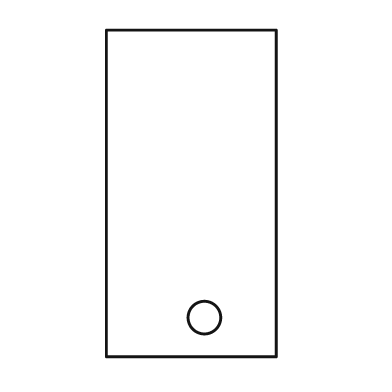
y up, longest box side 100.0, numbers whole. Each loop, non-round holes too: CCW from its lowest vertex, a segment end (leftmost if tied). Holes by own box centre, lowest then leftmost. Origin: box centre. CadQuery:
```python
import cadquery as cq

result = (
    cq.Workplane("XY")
    .moveTo(-26.0, -50.0)
    .lineTo(26.0, -50.0)
    .lineTo(26.0, 50.0)
    .lineTo(-26.0, 50.0)
    .close()
    .moveTo(4.0, -38.0)
    .circle(5.0)
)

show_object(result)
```